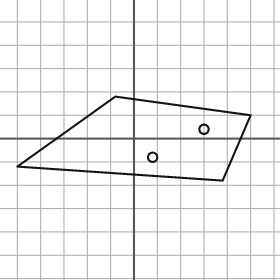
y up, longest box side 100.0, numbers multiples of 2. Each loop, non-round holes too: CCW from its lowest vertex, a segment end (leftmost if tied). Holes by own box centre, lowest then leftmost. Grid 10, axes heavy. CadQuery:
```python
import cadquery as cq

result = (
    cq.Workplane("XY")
    .moveTo(38.0, -18.0)
    .lineTo(50.0, 10.0)
    .lineTo(-8.0, 18.0)
    .lineTo(-50.0, -12.0)
    .close()
    .moveTo(8.0, -8.0)
    .circle(2.0)
    .moveTo(30.0, 4.0)
    .circle(2.0)
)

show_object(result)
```